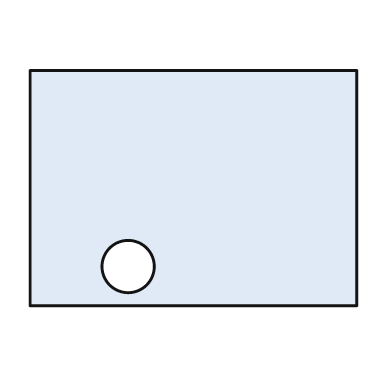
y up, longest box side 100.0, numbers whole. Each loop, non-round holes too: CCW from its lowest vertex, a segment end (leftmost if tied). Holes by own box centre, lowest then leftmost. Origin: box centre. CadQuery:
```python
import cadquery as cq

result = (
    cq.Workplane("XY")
    .moveTo(-50.0, -36.0)
    .lineTo(50.0, -36.0)
    .lineTo(50.0, 36.0)
    .lineTo(-50.0, 36.0)
    .close()
    .moveTo(-20.0, -24.0)
    .circle(8.0)
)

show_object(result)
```